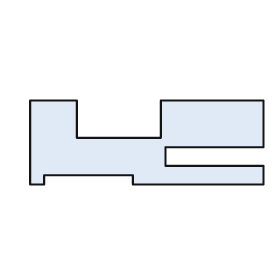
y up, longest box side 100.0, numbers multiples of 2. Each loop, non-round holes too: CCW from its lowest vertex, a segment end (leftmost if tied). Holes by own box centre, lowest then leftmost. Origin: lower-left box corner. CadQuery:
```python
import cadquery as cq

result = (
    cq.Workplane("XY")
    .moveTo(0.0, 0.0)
    .lineTo(6.0, 0.0)
    .lineTo(6.0, 4.0)
    .lineTo(44.0, 4.0)
    .lineTo(44.0, 0.0)
    .lineTo(100.0, 0.0)
    .lineTo(100.0, 8.0)
    .lineTo(58.0, 8.0)
    .lineTo(58.0, 16.0)
    .lineTo(100.0, 16.0)
    .lineTo(100.0, 36.0)
    .lineTo(56.0, 36.0)
    .lineTo(56.0, 20.0)
    .lineTo(20.0, 20.0)
    .lineTo(20.0, 36.0)
    .lineTo(0.0, 36.0)
    .close()
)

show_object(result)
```